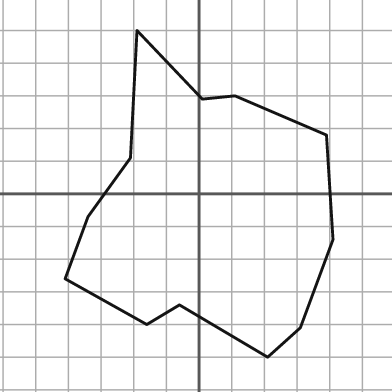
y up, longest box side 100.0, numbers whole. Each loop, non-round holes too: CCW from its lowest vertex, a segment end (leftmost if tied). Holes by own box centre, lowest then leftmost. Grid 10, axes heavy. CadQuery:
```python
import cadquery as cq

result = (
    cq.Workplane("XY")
    .moveTo(21.0, -50.0)
    .lineTo(31.0, -41.0)
    .lineTo(41.0, -14.0)
    .lineTo(39.0, 18.0)
    .lineTo(11.0, 30.0)
    .lineTo(1.0, 29.0)
    .lineTo(-19.0, 50.0)
    .lineTo(-21.0, 11.0)
    .lineTo(-34.0, -7.0)
    .lineTo(-41.0, -26.0)
    .lineTo(-16.0, -40.0)
    .lineTo(-6.0, -34.0)
    .close()
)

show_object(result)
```